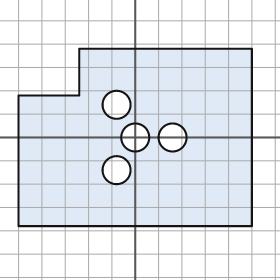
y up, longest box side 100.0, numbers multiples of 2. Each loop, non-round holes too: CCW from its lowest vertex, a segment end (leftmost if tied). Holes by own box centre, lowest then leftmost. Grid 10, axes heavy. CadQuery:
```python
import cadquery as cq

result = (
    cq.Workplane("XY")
    .moveTo(-50.0, -38.0)
    .lineTo(50.0, -38.0)
    .lineTo(50.0, 38.0)
    .lineTo(-24.0, 38.0)
    .lineTo(-24.0, 18.0)
    .lineTo(-50.0, 18.0)
    .close()
    .moveTo(-8.0, -14.0)
    .circle(6.0)
    .moveTo(0.0, 0.0)
    .circle(6.0)
    .moveTo(16.0, 0.0)
    .circle(6.0)
    .moveTo(-8.0, 14.0)
    .circle(6.0)
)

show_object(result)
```